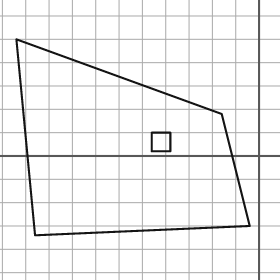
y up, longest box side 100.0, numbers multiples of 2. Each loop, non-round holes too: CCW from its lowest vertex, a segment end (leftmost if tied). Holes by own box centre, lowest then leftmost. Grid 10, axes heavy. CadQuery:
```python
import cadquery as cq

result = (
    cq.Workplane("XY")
    .moveTo(-96.0, -34.0)
    .lineTo(-4.0, -30.0)
    .lineTo(-16.0, 18.0)
    .lineTo(-104.0, 50.0)
    .close()
    .moveTo(-46.0, 2.0)
    .lineTo(-38.0, 2.0)
    .lineTo(-38.0, 10.0)
    .lineTo(-46.0, 10.0)
    .close()
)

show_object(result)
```